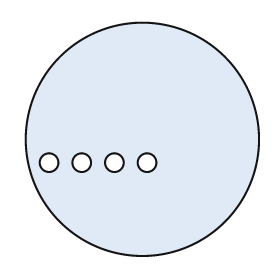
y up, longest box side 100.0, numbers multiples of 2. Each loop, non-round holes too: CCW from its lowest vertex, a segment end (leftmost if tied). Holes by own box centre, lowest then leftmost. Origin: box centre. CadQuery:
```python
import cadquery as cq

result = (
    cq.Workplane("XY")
    .moveTo(0.0, 0.0)
    .circle(50.0)
    .moveTo(-40.0, -10.0)
    .circle(4.0)
    .moveTo(-26.0, -10.0)
    .circle(4.0)
    .moveTo(-12.0, -10.0)
    .circle(4.0)
    .moveTo(2.0, -10.0)
    .circle(4.0)
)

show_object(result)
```